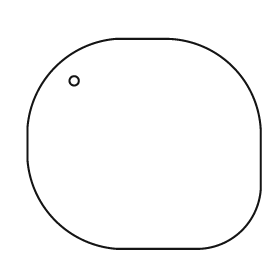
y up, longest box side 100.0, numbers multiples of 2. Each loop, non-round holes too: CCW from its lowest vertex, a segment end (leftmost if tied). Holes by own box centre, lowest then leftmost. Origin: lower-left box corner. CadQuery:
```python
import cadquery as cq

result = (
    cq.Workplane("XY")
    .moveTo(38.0, 0.0)
    .lineTo(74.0, 0.0)
    .threePointArc((92.0, 8.0), (100.0, 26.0))
    .lineTo(100.0, 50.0)
    .threePointArc((88.0, 78.0), (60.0, 90.0))
    .lineTo(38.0, 90.0)
    .threePointArc((12.0, 78.0), (0.0, 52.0))
    .lineTo(0.0, 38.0)
    .threePointArc((12.0, 12.0), (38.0, 0.0))
    .close()
    .moveTo(20.0, 72.0)
    .circle(2.0)
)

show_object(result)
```